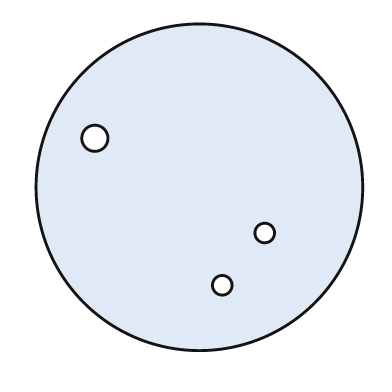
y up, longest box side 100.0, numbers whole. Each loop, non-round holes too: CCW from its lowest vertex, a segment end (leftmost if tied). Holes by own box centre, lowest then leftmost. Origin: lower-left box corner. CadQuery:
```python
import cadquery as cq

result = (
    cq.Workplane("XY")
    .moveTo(50.0, 50.0)
    .circle(50.0)
    .moveTo(57.0, 20.0)
    .circle(3.0)
    .moveTo(70.0, 36.0)
    .circle(3.0)
    .moveTo(18.0, 65.0)
    .circle(4.0)
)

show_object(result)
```